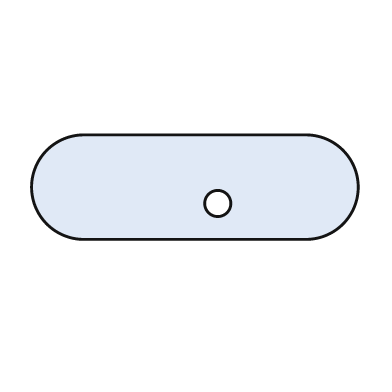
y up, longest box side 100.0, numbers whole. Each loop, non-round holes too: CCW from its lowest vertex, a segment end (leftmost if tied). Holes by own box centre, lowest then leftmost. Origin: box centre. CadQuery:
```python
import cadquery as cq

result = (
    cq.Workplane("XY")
    .moveTo(-34.0, -16.0)
    .lineTo(34.0, -16.0)
    .threePointArc((50.0, 0.0), (34.0, 16.0))
    .lineTo(-34.0, 16.0)
    .threePointArc((-50.0, 0.0), (-34.0, -16.0))
    .close()
    .moveTo(7.0, -5.0)
    .circle(4.0)
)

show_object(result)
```